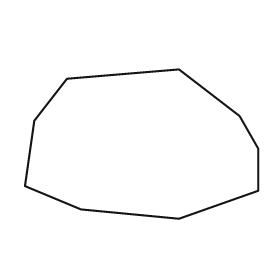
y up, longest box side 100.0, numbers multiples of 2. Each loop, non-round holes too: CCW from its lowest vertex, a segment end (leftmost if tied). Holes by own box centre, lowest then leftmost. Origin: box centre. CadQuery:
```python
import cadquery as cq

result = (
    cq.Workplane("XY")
    .moveTo(16.0, -32.0)
    .lineTo(50.0, -20.0)
    .lineTo(50.0, -2.0)
    .lineTo(42.0, 12.0)
    .lineTo(16.0, 32.0)
    .lineTo(-32.0, 28.0)
    .lineTo(-46.0, 10.0)
    .lineTo(-50.0, -18.0)
    .lineTo(-26.0, -28.0)
    .close()
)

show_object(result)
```